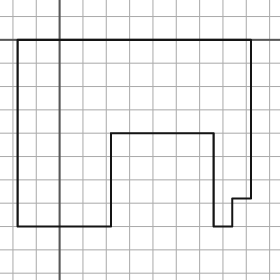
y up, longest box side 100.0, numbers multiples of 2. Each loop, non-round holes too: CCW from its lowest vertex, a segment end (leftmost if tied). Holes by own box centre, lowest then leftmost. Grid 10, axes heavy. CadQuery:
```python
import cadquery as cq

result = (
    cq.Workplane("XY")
    .moveTo(-18.0, -80.0)
    .lineTo(22.0, -80.0)
    .lineTo(22.0, -40.0)
    .lineTo(66.0, -40.0)
    .lineTo(66.0, -80.0)
    .lineTo(74.0, -80.0)
    .lineTo(74.0, -68.0)
    .lineTo(82.0, -68.0)
    .lineTo(82.0, 0.0)
    .lineTo(-18.0, 0.0)
    .close()
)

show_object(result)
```